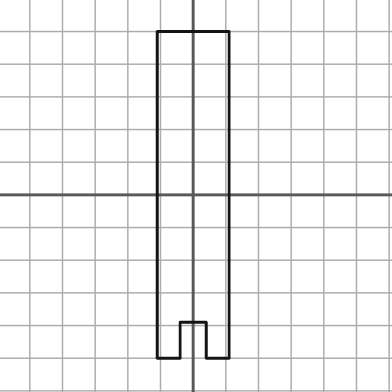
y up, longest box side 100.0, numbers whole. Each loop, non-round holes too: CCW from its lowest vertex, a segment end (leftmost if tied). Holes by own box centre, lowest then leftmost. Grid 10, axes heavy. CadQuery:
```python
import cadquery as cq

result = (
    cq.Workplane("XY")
    .moveTo(-11.0, -50.0)
    .lineTo(-4.0, -50.0)
    .lineTo(-4.0, -39.0)
    .lineTo(4.0, -39.0)
    .lineTo(4.0, -50.0)
    .lineTo(11.0, -50.0)
    .lineTo(11.0, 50.0)
    .lineTo(-11.0, 50.0)
    .close()
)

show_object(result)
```